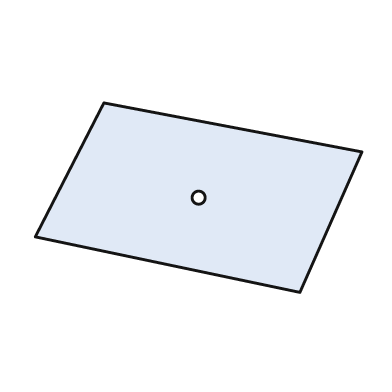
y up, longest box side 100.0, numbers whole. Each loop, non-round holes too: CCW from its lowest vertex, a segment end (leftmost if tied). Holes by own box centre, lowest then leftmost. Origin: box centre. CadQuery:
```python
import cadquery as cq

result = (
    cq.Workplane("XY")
    .moveTo(31.0, -29.0)
    .lineTo(50.0, 14.0)
    .lineTo(-29.0, 29.0)
    .lineTo(-50.0, -12.0)
    .close()
    .moveTo(0.0, 0.0)
    .circle(2.0)
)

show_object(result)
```